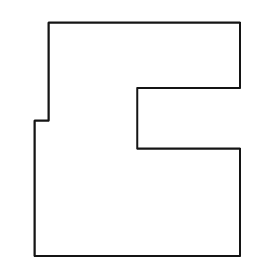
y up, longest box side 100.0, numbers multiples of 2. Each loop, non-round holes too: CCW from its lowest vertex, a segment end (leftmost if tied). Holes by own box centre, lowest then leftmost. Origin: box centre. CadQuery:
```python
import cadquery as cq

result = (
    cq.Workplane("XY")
    .moveTo(-44.0, -50.0)
    .lineTo(44.0, -50.0)
    .lineTo(44.0, -4.0)
    .lineTo(0.0, -4.0)
    .lineTo(0.0, 22.0)
    .lineTo(44.0, 22.0)
    .lineTo(44.0, 50.0)
    .lineTo(-38.0, 50.0)
    .lineTo(-38.0, 8.0)
    .lineTo(-44.0, 8.0)
    .close()
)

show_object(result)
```